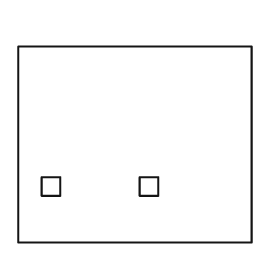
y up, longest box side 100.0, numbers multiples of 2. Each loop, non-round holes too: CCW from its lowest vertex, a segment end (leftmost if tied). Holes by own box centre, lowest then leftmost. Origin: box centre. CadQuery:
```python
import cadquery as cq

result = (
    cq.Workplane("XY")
    .moveTo(-50.0, -42.0)
    .lineTo(50.0, -42.0)
    .lineTo(50.0, 42.0)
    .lineTo(-50.0, 42.0)
    .close()
    .moveTo(-40.0, -22.0)
    .lineTo(-32.0, -22.0)
    .lineTo(-32.0, -14.0)
    .lineTo(-40.0, -14.0)
    .close()
    .moveTo(2.0, -22.0)
    .lineTo(10.0, -22.0)
    .lineTo(10.0, -14.0)
    .lineTo(2.0, -14.0)
    .close()
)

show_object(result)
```